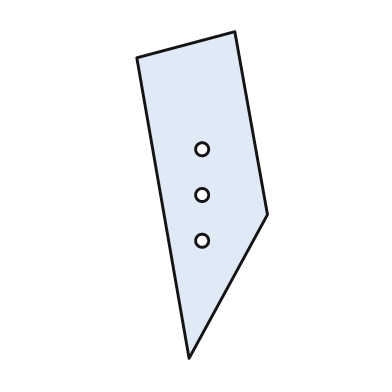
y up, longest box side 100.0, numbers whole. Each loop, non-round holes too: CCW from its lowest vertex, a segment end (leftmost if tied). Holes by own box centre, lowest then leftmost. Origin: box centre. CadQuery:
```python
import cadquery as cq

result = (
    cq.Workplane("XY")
    .moveTo(-4.0, -50.0)
    .lineTo(20.0, -6.0)
    .lineTo(10.0, 50.0)
    .lineTo(-20.0, 42.0)
    .close()
    .moveTo(0.0, -14.0)
    .circle(2.0)
    .moveTo(0.0, 0.0)
    .circle(2.0)
    .moveTo(0.0, 14.0)
    .circle(2.0)
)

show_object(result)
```